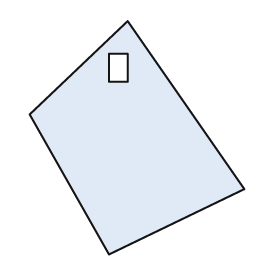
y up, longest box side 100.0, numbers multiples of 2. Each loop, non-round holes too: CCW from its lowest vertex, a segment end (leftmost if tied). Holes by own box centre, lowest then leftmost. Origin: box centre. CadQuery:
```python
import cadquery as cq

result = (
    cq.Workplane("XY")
    .moveTo(-12.0, -50.0)
    .lineTo(46.0, -22.0)
    .lineTo(-4.0, 50.0)
    .lineTo(-46.0, 10.0)
    .close()
    .moveTo(-12.0, 24.0)
    .lineTo(-4.0, 24.0)
    .lineTo(-4.0, 36.0)
    .lineTo(-12.0, 36.0)
    .close()
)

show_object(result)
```